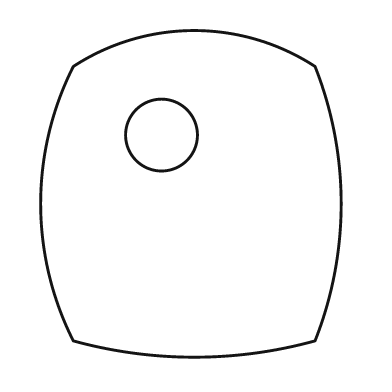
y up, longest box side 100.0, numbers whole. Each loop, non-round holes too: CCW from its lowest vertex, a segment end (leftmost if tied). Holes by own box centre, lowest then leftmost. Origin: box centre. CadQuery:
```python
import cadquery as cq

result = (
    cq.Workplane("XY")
    .moveTo(-36.0, -45.0)
    .threePointArc((1.0, -50.0), (38.0, -45.0))
    .threePointArc((46.0, -3.0), (38.0, 39.0))
    .threePointArc((1.0, 50.0), (-36.0, 39.0))
    .threePointArc((-46.0, -3.0), (-36.0, -45.0))
    .close()
    .moveTo(-9.0, 18.0)
    .circle(11.0)
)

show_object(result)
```